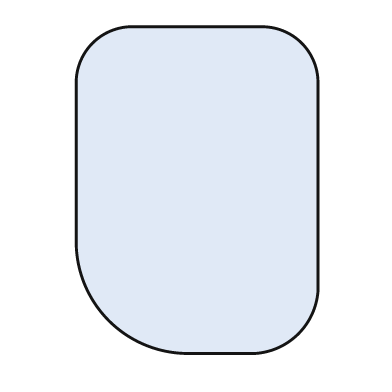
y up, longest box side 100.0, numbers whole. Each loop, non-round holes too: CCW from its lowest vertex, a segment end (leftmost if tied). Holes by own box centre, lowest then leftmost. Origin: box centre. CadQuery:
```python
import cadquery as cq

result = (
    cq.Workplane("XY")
    .moveTo(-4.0, -50.0)
    .lineTo(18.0, -50.0)
    .threePointArc((31.0, -44.0), (37.0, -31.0))
    .lineTo(37.0, 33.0)
    .threePointArc((32.0, 45.0), (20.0, 50.0))
    .lineTo(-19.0, 50.0)
    .threePointArc((-32.0, 45.0), (-37.0, 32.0))
    .lineTo(-37.0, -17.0)
    .threePointArc((-27.0, -40.0), (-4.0, -50.0))
    .close()
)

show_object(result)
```